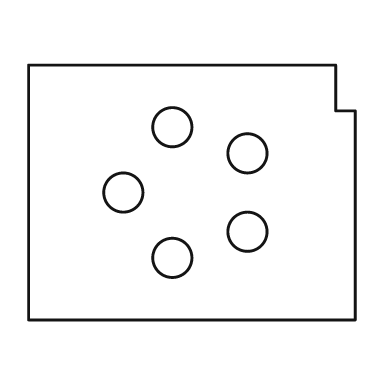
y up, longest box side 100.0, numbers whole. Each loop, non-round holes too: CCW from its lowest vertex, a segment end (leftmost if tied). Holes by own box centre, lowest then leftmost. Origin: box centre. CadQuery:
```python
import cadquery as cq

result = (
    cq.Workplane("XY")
    .moveTo(-50.0, -39.0)
    .lineTo(50.0, -39.0)
    .lineTo(50.0, 25.0)
    .lineTo(44.0, 25.0)
    .lineTo(44.0, 39.0)
    .lineTo(-50.0, 39.0)
    .close()
    .moveTo(-6.0, -20.0)
    .circle(6.0)
    .moveTo(17.0, -12.0)
    .circle(6.0)
    .moveTo(-21.0, 0.0)
    .circle(6.0)
    .moveTo(17.0, 12.0)
    .circle(6.0)
    .moveTo(-6.0, 20.0)
    .circle(6.0)
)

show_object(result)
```